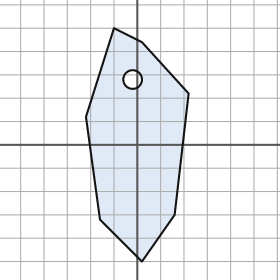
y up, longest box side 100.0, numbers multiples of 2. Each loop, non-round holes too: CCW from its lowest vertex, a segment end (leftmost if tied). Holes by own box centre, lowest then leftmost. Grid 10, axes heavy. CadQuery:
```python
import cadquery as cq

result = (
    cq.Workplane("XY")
    .moveTo(2.0, -50.0)
    .lineTo(16.0, -30.0)
    .lineTo(22.0, 22.0)
    .lineTo(2.0, 44.0)
    .lineTo(-10.0, 50.0)
    .lineTo(-22.0, 12.0)
    .lineTo(-16.0, -32.0)
    .close()
    .moveTo(-2.0, 28.0)
    .circle(4.0)
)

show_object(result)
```